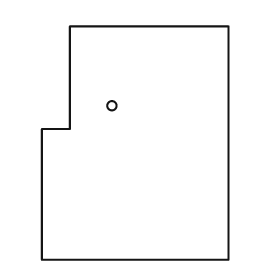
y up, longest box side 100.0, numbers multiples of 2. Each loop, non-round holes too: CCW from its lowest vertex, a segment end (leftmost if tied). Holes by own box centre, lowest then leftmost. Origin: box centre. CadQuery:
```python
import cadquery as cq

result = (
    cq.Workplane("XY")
    .moveTo(-40.0, -50.0)
    .lineTo(40.0, -50.0)
    .lineTo(40.0, 50.0)
    .lineTo(-28.0, 50.0)
    .lineTo(-28.0, 6.0)
    .lineTo(-40.0, 6.0)
    .close()
    .moveTo(-10.0, 16.0)
    .circle(2.0)
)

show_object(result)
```